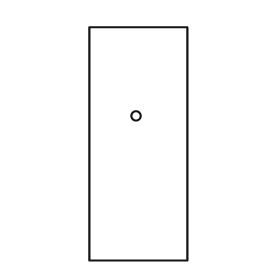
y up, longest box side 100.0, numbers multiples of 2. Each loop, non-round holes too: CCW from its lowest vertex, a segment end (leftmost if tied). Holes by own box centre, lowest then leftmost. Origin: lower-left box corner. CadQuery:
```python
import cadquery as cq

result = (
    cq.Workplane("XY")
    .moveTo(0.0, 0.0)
    .lineTo(42.0, 0.0)
    .lineTo(42.0, 100.0)
    .lineTo(0.0, 100.0)
    .close()
    .moveTo(20.0, 62.0)
    .circle(2.0)
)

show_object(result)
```